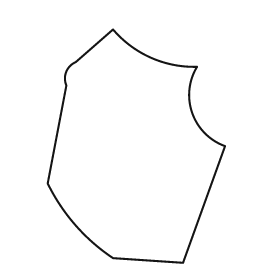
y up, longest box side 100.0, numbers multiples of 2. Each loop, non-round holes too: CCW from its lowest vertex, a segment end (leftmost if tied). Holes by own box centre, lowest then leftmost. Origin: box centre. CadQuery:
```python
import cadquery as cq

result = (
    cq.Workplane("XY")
    .moveTo(20.0, -50.0)
    .lineTo(38.0, 0.0)
    .threePointArc((24.0, 14.0), (26.0, 34.0))
    .threePointArc((6.0, 38.0), (-10.0, 50.0))
    .lineTo(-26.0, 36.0)
    .threePointArc((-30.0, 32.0), (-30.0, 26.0))
    .lineTo(-38.0, -16.0)
    .threePointArc((-26.0, -34.0), (-10.0, -48.0))
    .close()
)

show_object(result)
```